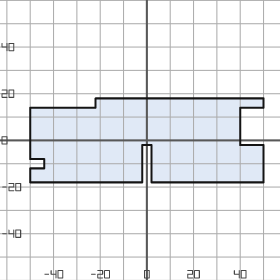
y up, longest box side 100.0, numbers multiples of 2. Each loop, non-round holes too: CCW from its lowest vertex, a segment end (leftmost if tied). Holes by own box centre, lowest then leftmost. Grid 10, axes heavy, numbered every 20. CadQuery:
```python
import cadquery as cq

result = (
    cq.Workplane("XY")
    .moveTo(-50.0, -18.0)
    .lineTo(-2.0, -18.0)
    .lineTo(-2.0, -2.0)
    .lineTo(2.0, -2.0)
    .lineTo(2.0, -18.0)
    .lineTo(50.0, -18.0)
    .lineTo(50.0, -2.0)
    .lineTo(40.0, -2.0)
    .lineTo(40.0, 14.0)
    .lineTo(50.0, 14.0)
    .lineTo(50.0, 18.0)
    .lineTo(-22.0, 18.0)
    .lineTo(-22.0, 14.0)
    .lineTo(-50.0, 14.0)
    .lineTo(-50.0, -8.0)
    .lineTo(-44.0, -8.0)
    .lineTo(-44.0, -12.0)
    .lineTo(-50.0, -12.0)
    .close()
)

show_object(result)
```